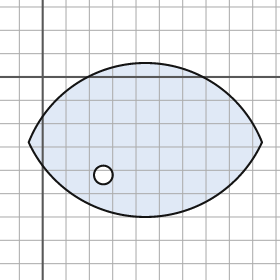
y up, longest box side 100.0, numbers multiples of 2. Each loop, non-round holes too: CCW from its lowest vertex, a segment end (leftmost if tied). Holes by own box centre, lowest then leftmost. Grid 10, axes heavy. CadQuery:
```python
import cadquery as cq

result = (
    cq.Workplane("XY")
    .moveTo(-6.0, -28.0)
    .threePointArc((44.0, -60.0), (94.0, -28.0))
    .threePointArc((44.0, 6.0), (-6.0, -28.0))
    .close()
    .moveTo(26.0, -42.0)
    .circle(4.0)
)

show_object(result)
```